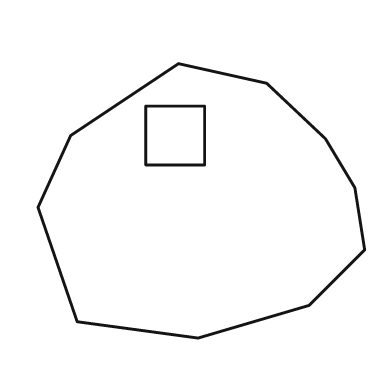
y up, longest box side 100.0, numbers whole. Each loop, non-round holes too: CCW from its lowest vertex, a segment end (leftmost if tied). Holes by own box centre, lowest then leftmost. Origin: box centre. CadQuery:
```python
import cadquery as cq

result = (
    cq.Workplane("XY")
    .moveTo(-1.0, -42.0)
    .lineTo(33.0, -32.0)
    .lineTo(50.0, -15.0)
    .lineTo(47.0, 4.0)
    .lineTo(38.0, 19.0)
    .lineTo(20.0, 36.0)
    .lineTo(-7.0, 42.0)
    .lineTo(-40.0, 20.0)
    .lineTo(-50.0, -2.0)
    .lineTo(-38.0, -37.0)
    .close()
    .moveTo(-17.0, 11.0)
    .lineTo(1.0, 11.0)
    .lineTo(1.0, 29.0)
    .lineTo(-17.0, 29.0)
    .close()
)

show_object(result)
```